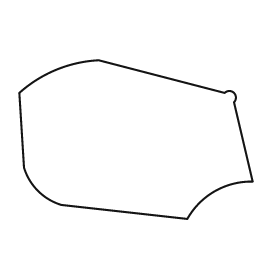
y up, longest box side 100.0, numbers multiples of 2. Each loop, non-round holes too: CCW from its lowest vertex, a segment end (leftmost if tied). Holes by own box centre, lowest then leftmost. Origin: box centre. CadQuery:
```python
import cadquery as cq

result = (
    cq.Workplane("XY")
    .moveTo(22.0, -34.0)
    .threePointArc((34.0, -22.0), (50.0, -18.0))
    .lineTo(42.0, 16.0)
    .threePointArc((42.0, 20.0), (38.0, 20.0))
    .lineTo(-16.0, 34.0)
    .threePointArc((-34.0, 30.0), (-50.0, 20.0))
    .lineTo(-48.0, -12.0)
    .threePointArc((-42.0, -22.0), (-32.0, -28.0))
    .close()
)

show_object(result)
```